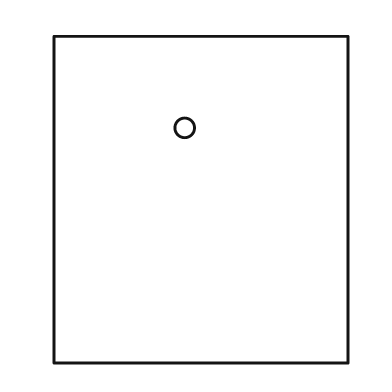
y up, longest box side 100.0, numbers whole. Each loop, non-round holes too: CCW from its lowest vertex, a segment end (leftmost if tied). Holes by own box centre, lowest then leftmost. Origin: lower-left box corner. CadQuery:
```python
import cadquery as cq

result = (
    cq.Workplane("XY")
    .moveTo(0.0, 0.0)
    .lineTo(90.0, 0.0)
    .lineTo(90.0, 100.0)
    .lineTo(0.0, 100.0)
    .close()
    .moveTo(40.0, 72.0)
    .circle(3.0)
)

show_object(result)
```